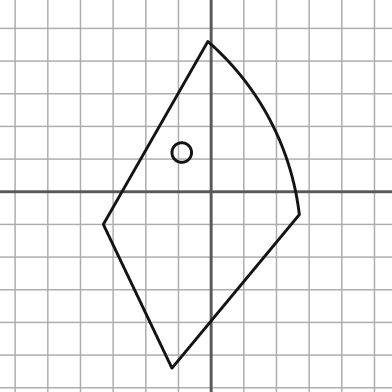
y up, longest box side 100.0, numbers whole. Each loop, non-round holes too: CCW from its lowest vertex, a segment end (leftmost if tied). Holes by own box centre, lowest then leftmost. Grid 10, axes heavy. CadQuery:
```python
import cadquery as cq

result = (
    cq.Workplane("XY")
    .moveTo(-12.0, -54.0)
    .lineTo(27.0, -7.0)
    .threePointArc((18.0, 22.0), (-1.0, 46.0))
    .lineTo(-33.0, -10.0)
    .close()
    .moveTo(-9.0, 12.0)
    .circle(3.0)
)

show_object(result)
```